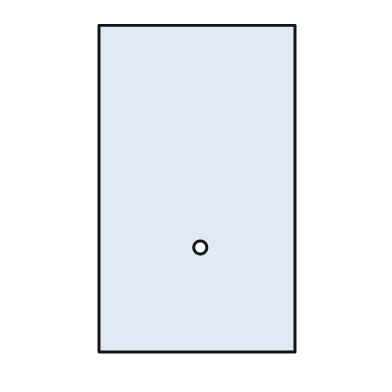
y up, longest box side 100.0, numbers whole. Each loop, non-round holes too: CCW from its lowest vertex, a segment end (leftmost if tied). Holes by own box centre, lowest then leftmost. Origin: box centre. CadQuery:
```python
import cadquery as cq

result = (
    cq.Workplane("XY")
    .moveTo(-30.0, -50.0)
    .lineTo(30.0, -50.0)
    .lineTo(30.0, 50.0)
    .lineTo(-30.0, 50.0)
    .close()
    .moveTo(1.0, -18.0)
    .circle(2.0)
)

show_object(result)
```